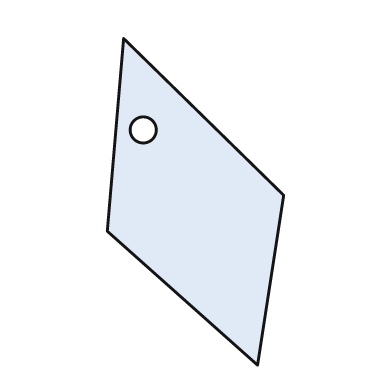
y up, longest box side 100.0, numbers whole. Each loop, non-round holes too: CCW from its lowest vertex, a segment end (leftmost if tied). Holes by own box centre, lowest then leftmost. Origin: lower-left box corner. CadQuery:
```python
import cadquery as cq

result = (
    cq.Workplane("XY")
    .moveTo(46.0, 0.0)
    .lineTo(54.0, 52.0)
    .lineTo(5.0, 100.0)
    .lineTo(0.0, 41.0)
    .close()
    .moveTo(11.0, 72.0)
    .circle(4.0)
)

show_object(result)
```